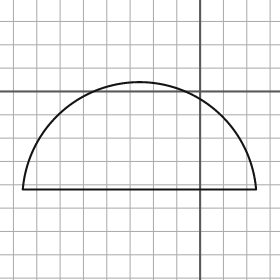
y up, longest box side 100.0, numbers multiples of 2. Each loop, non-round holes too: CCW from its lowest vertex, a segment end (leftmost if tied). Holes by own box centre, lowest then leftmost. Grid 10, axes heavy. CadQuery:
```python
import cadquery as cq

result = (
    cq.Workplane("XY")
    .moveTo(-76.0, -42.0)
    .lineTo(24.0, -42.0)
    .threePointArc((-26.0, 4.0), (-76.0, -42.0))
    .close()
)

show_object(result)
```